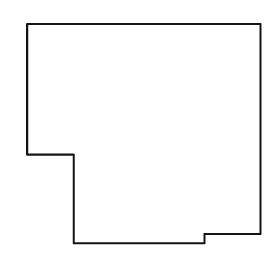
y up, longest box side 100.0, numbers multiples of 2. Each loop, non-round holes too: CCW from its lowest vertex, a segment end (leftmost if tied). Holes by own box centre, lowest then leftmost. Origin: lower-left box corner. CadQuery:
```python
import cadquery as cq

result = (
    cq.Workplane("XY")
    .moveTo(20.0, 0.0)
    .lineTo(76.0, 0.0)
    .lineTo(76.0, 4.0)
    .lineTo(100.0, 4.0)
    .lineTo(100.0, 94.0)
    .lineTo(0.0, 94.0)
    .lineTo(0.0, 38.0)
    .lineTo(20.0, 38.0)
    .close()
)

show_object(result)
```